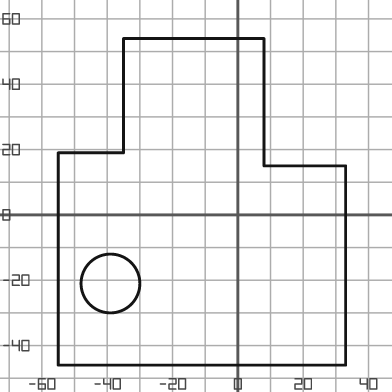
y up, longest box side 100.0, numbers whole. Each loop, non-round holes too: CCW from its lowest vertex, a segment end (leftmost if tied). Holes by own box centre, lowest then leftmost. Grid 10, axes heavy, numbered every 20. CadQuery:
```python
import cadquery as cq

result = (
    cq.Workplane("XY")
    .moveTo(-55.0, -46.0)
    .lineTo(33.0, -46.0)
    .lineTo(33.0, 15.0)
    .lineTo(8.0, 15.0)
    .lineTo(8.0, 54.0)
    .lineTo(-35.0, 54.0)
    .lineTo(-35.0, 19.0)
    .lineTo(-55.0, 19.0)
    .close()
    .moveTo(-39.0, -21.0)
    .circle(9.0)
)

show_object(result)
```